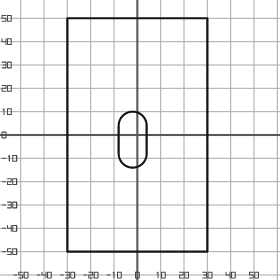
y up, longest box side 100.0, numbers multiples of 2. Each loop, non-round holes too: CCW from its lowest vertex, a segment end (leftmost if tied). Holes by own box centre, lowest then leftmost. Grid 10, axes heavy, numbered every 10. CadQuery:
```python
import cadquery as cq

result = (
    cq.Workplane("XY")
    .moveTo(-30.0, -50.0)
    .lineTo(30.0, -50.0)
    .lineTo(30.0, 50.0)
    .lineTo(-30.0, 50.0)
    .close()
    .moveTo(-8.0, -8.0)
    .threePointArc((-2.0, -14.0), (4.0, -8.0))
    .lineTo(4.0, 4.0)
    .threePointArc((-2.0, 10.0), (-8.0, 4.0))
    .close()
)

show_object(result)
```